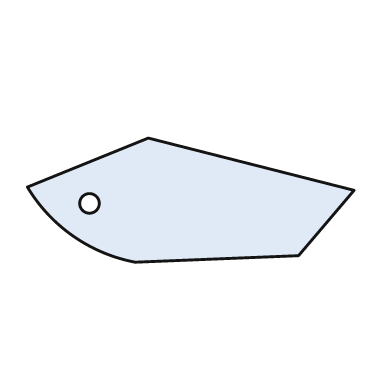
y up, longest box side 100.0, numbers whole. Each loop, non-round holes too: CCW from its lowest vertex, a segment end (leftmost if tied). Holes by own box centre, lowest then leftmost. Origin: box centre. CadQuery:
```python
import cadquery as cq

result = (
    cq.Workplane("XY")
    .moveTo(-17.0, -19.0)
    .lineTo(33.0, -17.0)
    .lineTo(50.0, 3.0)
    .lineTo(-13.0, 19.0)
    .lineTo(-50.0, 4.0)
    .threePointArc((-36.0, -11.0), (-17.0, -19.0))
    .close()
    .moveTo(-31.0, -1.0)
    .circle(3.0)
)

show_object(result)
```